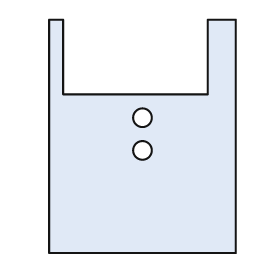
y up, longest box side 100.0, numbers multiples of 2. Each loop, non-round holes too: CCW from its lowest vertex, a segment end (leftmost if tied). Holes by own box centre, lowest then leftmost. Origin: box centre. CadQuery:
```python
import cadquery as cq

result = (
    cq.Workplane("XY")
    .moveTo(-40.0, -50.0)
    .lineTo(40.0, -50.0)
    .lineTo(40.0, 50.0)
    .lineTo(28.0, 50.0)
    .lineTo(28.0, 18.0)
    .lineTo(-34.0, 18.0)
    .lineTo(-34.0, 50.0)
    .lineTo(-40.0, 50.0)
    .close()
    .moveTo(0.0, -6.0)
    .circle(4.0)
    .moveTo(0.0, 8.0)
    .circle(4.0)
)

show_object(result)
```